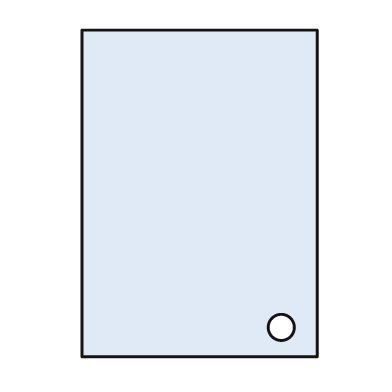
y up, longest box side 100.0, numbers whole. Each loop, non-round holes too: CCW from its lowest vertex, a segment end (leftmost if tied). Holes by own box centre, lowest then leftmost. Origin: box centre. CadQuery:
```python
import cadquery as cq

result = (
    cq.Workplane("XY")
    .moveTo(-36.0, -50.0)
    .lineTo(36.0, -50.0)
    .lineTo(36.0, 50.0)
    .lineTo(-36.0, 50.0)
    .close()
    .moveTo(25.0, -41.0)
    .circle(4.0)
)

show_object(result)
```